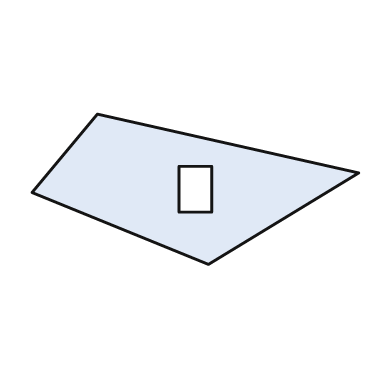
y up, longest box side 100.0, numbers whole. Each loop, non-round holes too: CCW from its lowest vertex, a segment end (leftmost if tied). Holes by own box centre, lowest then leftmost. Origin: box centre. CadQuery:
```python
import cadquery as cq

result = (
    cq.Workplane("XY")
    .moveTo(4.0, -23.0)
    .lineTo(50.0, 5.0)
    .lineTo(-30.0, 23.0)
    .lineTo(-50.0, -1.0)
    .close()
    .moveTo(-5.0, -7.0)
    .lineTo(5.0, -7.0)
    .lineTo(5.0, 7.0)
    .lineTo(-5.0, 7.0)
    .close()
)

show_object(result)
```